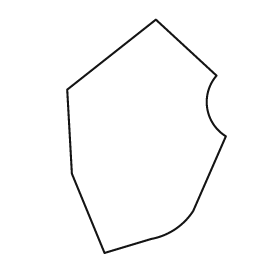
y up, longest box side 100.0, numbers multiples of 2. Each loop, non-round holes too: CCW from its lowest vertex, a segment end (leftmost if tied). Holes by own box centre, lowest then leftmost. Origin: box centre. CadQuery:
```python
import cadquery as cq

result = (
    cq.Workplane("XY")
    .moveTo(-18.0, -50.0)
    .lineTo(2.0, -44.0)
    .threePointArc((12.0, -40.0), (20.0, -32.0))
    .lineTo(34.0, 0.0)
    .threePointArc((26.0, 12.0), (30.0, 26.0))
    .lineTo(4.0, 50.0)
    .lineTo(-34.0, 20.0)
    .lineTo(-32.0, -16.0)
    .close()
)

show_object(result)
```